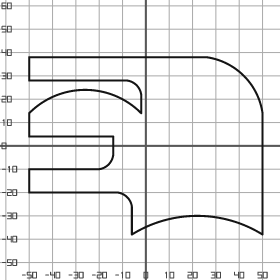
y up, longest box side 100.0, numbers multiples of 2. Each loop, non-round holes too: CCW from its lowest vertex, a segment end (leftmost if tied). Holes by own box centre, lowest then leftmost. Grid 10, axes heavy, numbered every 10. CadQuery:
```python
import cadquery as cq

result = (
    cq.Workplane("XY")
    .moveTo(-6.0, -38.0)
    .threePointArc((22.0, -30.0), (50.0, -38.0))
    .lineTo(50.0, 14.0)
    .threePointArc((42.0, 30.0), (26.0, 38.0))
    .lineTo(-50.0, 38.0)
    .lineTo(-50.0, 28.0)
    .lineTo(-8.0, 28.0)
    .threePointArc((-4.0, 26.0), (-2.0, 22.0))
    .lineTo(-2.0, 14.0)
    .threePointArc((-26.0, 24.0), (-50.0, 14.0))
    .lineTo(-50.0, 4.0)
    .lineTo(-14.0, 4.0)
    .lineTo(-14.0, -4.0)
    .threePointArc((-16.0, -8.0), (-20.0, -10.0))
    .lineTo(-50.0, -10.0)
    .lineTo(-50.0, -20.0)
    .lineTo(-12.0, -20.0)
    .threePointArc((-8.0, -22.0), (-6.0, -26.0))
    .close()
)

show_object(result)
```